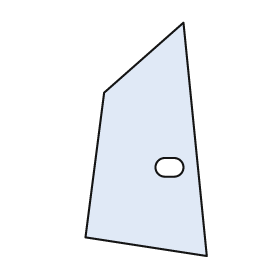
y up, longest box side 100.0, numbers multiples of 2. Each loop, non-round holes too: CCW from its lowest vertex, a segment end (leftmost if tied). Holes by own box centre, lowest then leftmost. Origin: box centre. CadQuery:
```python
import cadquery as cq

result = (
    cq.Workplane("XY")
    .moveTo(26.0, -50.0)
    .lineTo(16.0, 50.0)
    .lineTo(-18.0, 20.0)
    .lineTo(-26.0, -42.0)
    .close()
    .moveTo(8.0, -16.0)
    .lineTo(12.0, -16.0)
    .threePointArc((16.0, -12.0), (12.0, -8.0))
    .lineTo(8.0, -8.0)
    .threePointArc((4.0, -12.0), (8.0, -16.0))
    .close()
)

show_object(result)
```